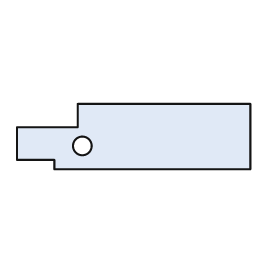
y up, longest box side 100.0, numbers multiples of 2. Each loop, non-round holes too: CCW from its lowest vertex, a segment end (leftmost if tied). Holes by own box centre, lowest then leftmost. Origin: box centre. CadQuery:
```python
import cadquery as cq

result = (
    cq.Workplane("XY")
    .moveTo(-34.0, -14.0)
    .lineTo(50.0, -14.0)
    .lineTo(50.0, 14.0)
    .lineTo(-24.0, 14.0)
    .lineTo(-24.0, 4.0)
    .lineTo(-50.0, 4.0)
    .lineTo(-50.0, -10.0)
    .lineTo(-34.0, -10.0)
    .close()
    .moveTo(-22.0, -4.0)
    .circle(4.0)
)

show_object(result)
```